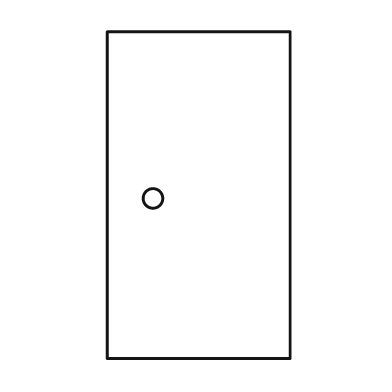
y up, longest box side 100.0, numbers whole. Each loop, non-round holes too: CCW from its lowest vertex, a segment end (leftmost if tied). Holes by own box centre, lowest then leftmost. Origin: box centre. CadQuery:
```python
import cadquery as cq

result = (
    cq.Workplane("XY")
    .moveTo(-28.0, -50.0)
    .lineTo(28.0, -50.0)
    .lineTo(28.0, 50.0)
    .lineTo(-28.0, 50.0)
    .close()
    .moveTo(-14.0, -1.0)
    .circle(3.0)
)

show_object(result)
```